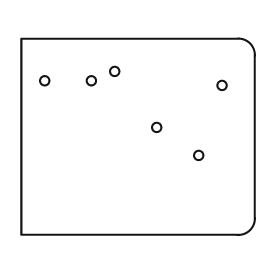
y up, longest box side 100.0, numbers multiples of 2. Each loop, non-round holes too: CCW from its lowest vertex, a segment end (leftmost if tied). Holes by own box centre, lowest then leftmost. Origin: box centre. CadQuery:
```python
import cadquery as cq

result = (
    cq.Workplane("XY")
    .moveTo(-50.0, -42.0)
    .lineTo(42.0, -42.0)
    .threePointArc((48.0, -40.0), (50.0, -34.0))
    .lineTo(50.0, 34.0)
    .threePointArc((48.0, 40.0), (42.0, 42.0))
    .lineTo(-50.0, 42.0)
    .close()
    .moveTo(26.0, -8.0)
    .circle(2.0)
    .moveTo(8.0, 4.0)
    .circle(2.0)
    .moveTo(36.0, 22.0)
    .circle(2.0)
    .moveTo(-40.0, 24.0)
    .circle(2.0)
    .moveTo(-20.0, 24.0)
    .circle(2.0)
    .moveTo(-10.0, 28.0)
    .circle(2.0)
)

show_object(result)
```